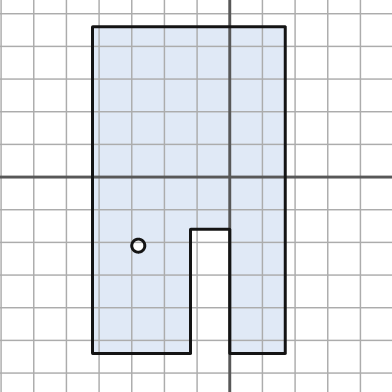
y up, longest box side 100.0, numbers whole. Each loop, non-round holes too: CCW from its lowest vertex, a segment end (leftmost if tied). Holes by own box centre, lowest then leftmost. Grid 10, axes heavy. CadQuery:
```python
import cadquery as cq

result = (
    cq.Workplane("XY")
    .moveTo(-42.0, -54.0)
    .lineTo(-12.0, -54.0)
    .lineTo(-12.0, -16.0)
    .lineTo(0.0, -16.0)
    .lineTo(0.0, -54.0)
    .lineTo(17.0, -54.0)
    .lineTo(17.0, 46.0)
    .lineTo(-42.0, 46.0)
    .close()
    .moveTo(-28.0, -21.0)
    .circle(2.0)
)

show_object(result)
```